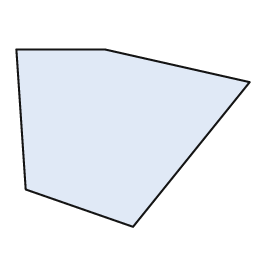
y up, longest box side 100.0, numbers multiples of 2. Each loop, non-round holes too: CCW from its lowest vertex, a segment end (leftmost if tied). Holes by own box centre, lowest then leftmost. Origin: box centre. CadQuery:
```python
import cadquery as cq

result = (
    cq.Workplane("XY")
    .moveTo(0.0, -38.0)
    .lineTo(50.0, 24.0)
    .lineTo(-12.0, 38.0)
    .lineTo(-50.0, 38.0)
    .lineTo(-46.0, -22.0)
    .close()
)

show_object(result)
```